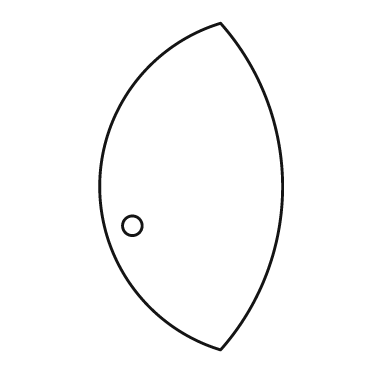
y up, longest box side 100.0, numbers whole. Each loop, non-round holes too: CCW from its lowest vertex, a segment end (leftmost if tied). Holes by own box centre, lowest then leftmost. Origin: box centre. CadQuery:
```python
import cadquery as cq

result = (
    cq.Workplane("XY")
    .moveTo(9.0, -50.0)
    .threePointArc((28.0, 0.0), (9.0, 50.0))
    .threePointArc((-28.0, 0.0), (9.0, -50.0))
    .close()
    .moveTo(-18.0, -12.0)
    .circle(3.0)
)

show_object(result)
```